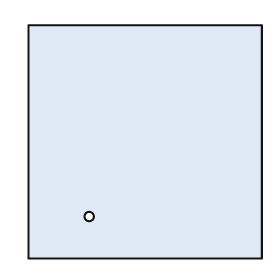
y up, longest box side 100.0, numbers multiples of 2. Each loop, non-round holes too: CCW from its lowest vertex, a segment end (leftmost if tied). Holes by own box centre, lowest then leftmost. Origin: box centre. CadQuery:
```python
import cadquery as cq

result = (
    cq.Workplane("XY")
    .moveTo(-50.0, -50.0)
    .lineTo(50.0, -50.0)
    .lineTo(50.0, 50.0)
    .lineTo(-50.0, 50.0)
    .close()
    .moveTo(-24.0, -32.0)
    .circle(2.0)
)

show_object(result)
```